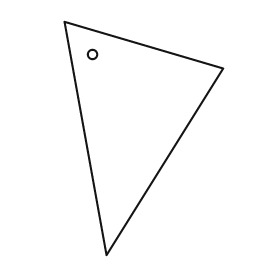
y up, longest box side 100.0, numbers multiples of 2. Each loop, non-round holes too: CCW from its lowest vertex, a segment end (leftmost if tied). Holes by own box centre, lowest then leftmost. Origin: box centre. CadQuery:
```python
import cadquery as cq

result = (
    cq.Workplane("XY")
    .moveTo(-16.0, -50.0)
    .lineTo(34.0, 30.0)
    .lineTo(-34.0, 50.0)
    .close()
    .moveTo(-22.0, 36.0)
    .circle(2.0)
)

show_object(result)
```